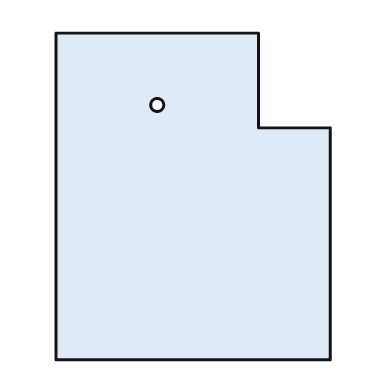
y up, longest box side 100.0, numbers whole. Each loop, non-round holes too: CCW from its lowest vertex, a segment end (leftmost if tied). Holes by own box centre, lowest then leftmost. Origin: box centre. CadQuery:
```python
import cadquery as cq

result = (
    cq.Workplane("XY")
    .moveTo(-42.0, -50.0)
    .lineTo(42.0, -50.0)
    .lineTo(42.0, 21.0)
    .lineTo(20.0, 21.0)
    .lineTo(20.0, 50.0)
    .lineTo(-42.0, 50.0)
    .close()
    .moveTo(-11.0, 28.0)
    .circle(2.0)
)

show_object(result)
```